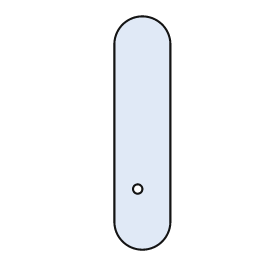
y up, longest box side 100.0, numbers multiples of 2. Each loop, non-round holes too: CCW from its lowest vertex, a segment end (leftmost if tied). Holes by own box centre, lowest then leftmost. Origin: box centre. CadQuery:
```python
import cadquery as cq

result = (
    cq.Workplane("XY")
    .moveTo(-12.0, -38.0)
    .threePointArc((0.0, -50.0), (12.0, -38.0))
    .lineTo(12.0, 38.0)
    .threePointArc((0.0, 50.0), (-12.0, 38.0))
    .close()
    .moveTo(-2.0, -24.0)
    .circle(2.0)
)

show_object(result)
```